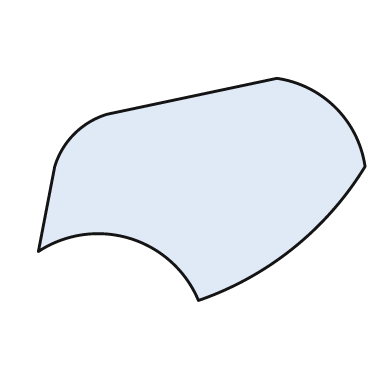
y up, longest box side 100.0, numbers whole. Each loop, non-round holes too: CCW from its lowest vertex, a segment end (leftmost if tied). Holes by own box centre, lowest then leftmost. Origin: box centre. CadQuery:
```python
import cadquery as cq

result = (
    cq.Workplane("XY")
    .moveTo(-1.0, -34.0)
    .threePointArc((28.0, -18.0), (50.0, 7.0))
    .threePointArc((41.0, 25.0), (23.0, 34.0))
    .lineTo(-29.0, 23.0)
    .threePointArc((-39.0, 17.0), (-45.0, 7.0))
    .lineTo(-50.0, -19.0)
    .threePointArc((-22.0, -15.0), (-1.0, -34.0))
    .close()
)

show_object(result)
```